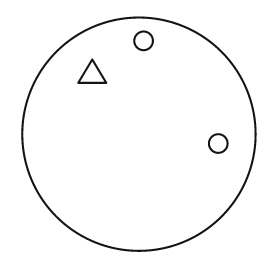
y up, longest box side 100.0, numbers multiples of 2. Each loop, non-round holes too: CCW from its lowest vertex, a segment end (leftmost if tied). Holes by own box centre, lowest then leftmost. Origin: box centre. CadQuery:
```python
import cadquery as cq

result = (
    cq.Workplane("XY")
    .moveTo(0.0, 0.0)
    .circle(50.0)
    .moveTo(34.0, -4.0)
    .circle(4.0)
    .moveTo(-26.0, 22.0)
    .lineTo(-14.0, 22.0)
    .lineTo(-20.0, 32.0)
    .close()
    .moveTo(2.0, 40.0)
    .circle(4.0)
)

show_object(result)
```